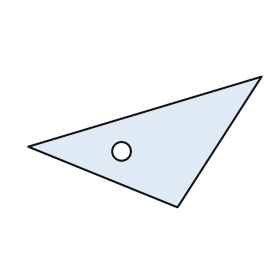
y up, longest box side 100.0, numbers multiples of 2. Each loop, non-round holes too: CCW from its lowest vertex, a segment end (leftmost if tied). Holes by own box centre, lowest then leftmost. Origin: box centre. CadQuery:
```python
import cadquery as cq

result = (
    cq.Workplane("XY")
    .moveTo(14.0, -28.0)
    .lineTo(50.0, 28.0)
    .lineTo(-50.0, -2.0)
    .close()
    .moveTo(-10.0, -4.0)
    .circle(4.0)
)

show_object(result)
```